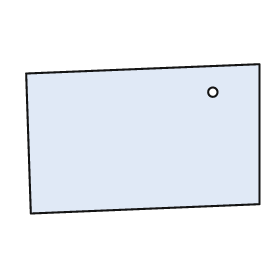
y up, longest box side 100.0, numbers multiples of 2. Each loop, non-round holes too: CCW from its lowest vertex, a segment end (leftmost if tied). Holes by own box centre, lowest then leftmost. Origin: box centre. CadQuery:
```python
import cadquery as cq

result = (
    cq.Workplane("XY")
    .moveTo(-48.0, -32.0)
    .lineTo(50.0, -28.0)
    .lineTo(50.0, 32.0)
    .lineTo(-50.0, 28.0)
    .close()
    .moveTo(30.0, 20.0)
    .circle(2.0)
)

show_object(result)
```